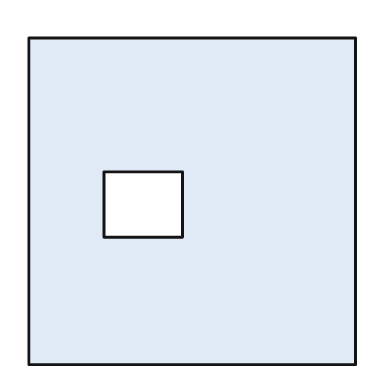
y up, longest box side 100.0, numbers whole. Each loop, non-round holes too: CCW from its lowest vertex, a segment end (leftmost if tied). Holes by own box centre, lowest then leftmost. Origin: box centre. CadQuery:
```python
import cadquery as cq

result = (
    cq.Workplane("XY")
    .moveTo(-50.0, -50.0)
    .lineTo(50.0, -50.0)
    .lineTo(50.0, 50.0)
    .lineTo(-50.0, 50.0)
    .close()
    .moveTo(-27.0, -11.0)
    .lineTo(-3.0, -11.0)
    .lineTo(-3.0, 9.0)
    .lineTo(-27.0, 9.0)
    .close()
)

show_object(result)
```